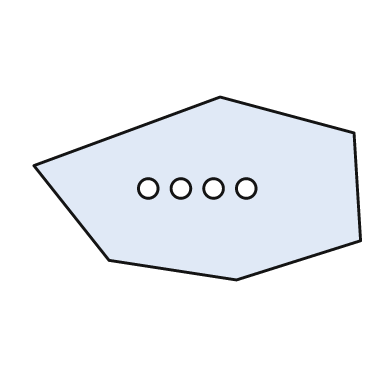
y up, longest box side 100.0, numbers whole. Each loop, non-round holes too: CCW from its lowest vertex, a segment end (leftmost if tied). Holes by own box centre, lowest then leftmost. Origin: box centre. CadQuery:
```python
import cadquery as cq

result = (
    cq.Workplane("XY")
    .moveTo(12.0, -28.0)
    .lineTo(50.0, -16.0)
    .lineTo(48.0, 17.0)
    .lineTo(7.0, 28.0)
    .lineTo(-50.0, 7.0)
    .lineTo(-27.0, -22.0)
    .close()
    .moveTo(-15.0, 0.0)
    .circle(3.0)
    .moveTo(-5.0, 0.0)
    .circle(3.0)
    .moveTo(5.0, 0.0)
    .circle(3.0)
    .moveTo(15.0, 0.0)
    .circle(3.0)
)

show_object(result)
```